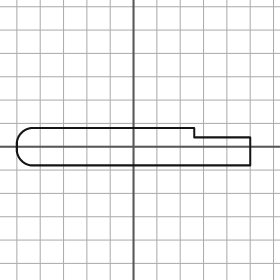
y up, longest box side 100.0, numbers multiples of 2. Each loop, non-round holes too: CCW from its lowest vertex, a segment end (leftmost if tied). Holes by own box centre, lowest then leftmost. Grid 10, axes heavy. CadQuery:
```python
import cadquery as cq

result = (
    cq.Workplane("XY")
    .moveTo(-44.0, -8.0)
    .lineTo(50.0, -8.0)
    .lineTo(50.0, 4.0)
    .lineTo(26.0, 4.0)
    .lineTo(26.0, 8.0)
    .lineTo(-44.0, 8.0)
    .threePointArc((-48.0, 6.0), (-50.0, 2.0))
    .lineTo(-50.0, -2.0)
    .threePointArc((-48.0, -6.0), (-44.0, -8.0))
    .close()
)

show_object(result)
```